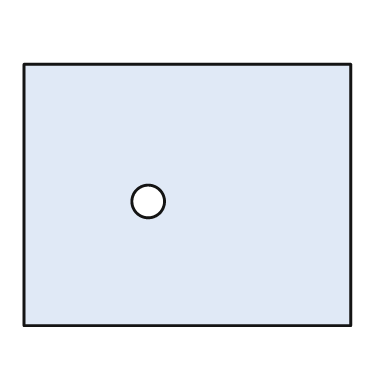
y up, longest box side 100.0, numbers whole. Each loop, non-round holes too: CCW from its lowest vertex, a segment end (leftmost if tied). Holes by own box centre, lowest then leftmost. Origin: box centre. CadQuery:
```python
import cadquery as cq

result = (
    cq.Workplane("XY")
    .moveTo(-50.0, -40.0)
    .lineTo(50.0, -40.0)
    .lineTo(50.0, 40.0)
    .lineTo(-50.0, 40.0)
    .close()
    .moveTo(-12.0, -2.0)
    .circle(5.0)
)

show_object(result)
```